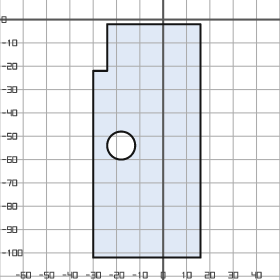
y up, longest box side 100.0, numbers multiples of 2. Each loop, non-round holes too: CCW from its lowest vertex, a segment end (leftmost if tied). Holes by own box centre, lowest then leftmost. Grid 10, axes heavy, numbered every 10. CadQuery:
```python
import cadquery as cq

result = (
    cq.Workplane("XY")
    .moveTo(-30.0, -102.0)
    .lineTo(16.0, -102.0)
    .lineTo(16.0, -2.0)
    .lineTo(-24.0, -2.0)
    .lineTo(-24.0, -22.0)
    .lineTo(-30.0, -22.0)
    .close()
    .moveTo(-18.0, -54.0)
    .circle(6.0)
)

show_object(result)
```